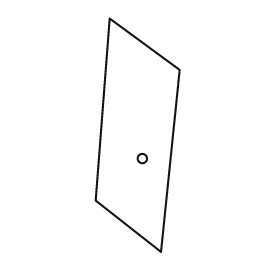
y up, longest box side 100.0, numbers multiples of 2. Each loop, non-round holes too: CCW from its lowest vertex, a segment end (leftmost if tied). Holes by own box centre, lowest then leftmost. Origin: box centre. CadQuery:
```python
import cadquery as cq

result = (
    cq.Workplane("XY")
    .moveTo(10.0, -50.0)
    .lineTo(18.0, 28.0)
    .lineTo(-12.0, 50.0)
    .lineTo(-18.0, -28.0)
    .close()
    .moveTo(2.0, -10.0)
    .circle(2.0)
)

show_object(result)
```